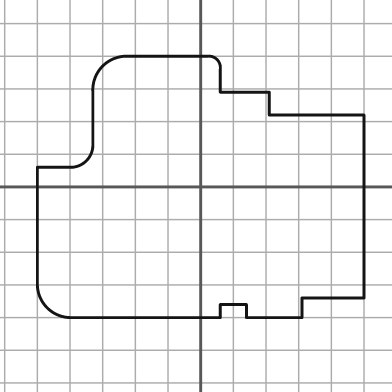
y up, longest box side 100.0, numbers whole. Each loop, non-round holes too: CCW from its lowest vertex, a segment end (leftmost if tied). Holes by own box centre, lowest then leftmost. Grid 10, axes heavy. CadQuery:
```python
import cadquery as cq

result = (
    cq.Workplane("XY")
    .moveTo(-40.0, -40.0)
    .lineTo(6.0, -40.0)
    .lineTo(6.0, -36.0)
    .lineTo(14.0, -36.0)
    .lineTo(14.0, -40.0)
    .lineTo(31.0, -40.0)
    .lineTo(31.0, -34.0)
    .lineTo(50.0, -34.0)
    .lineTo(50.0, 22.0)
    .lineTo(21.0, 22.0)
    .lineTo(21.0, 29.0)
    .lineTo(6.0, 29.0)
    .lineTo(6.0, 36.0)
    .threePointArc((5.0, 39.0), (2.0, 40.0))
    .lineTo(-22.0, 40.0)
    .threePointArc((-30.0, 37.0), (-33.0, 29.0))
    .lineTo(-33.0, 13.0)
    .threePointArc((-35.0, 8.0), (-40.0, 6.0))
    .lineTo(-50.0, 6.0)
    .lineTo(-50.0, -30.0)
    .threePointArc((-47.0, -37.0), (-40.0, -40.0))
    .close()
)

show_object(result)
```